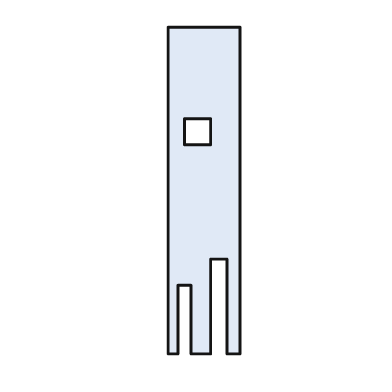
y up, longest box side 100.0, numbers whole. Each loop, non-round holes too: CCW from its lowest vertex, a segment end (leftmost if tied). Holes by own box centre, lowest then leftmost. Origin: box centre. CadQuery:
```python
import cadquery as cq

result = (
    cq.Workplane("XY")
    .moveTo(-11.0, -50.0)
    .lineTo(-8.0, -50.0)
    .lineTo(-8.0, -29.0)
    .lineTo(-4.0, -29.0)
    .lineTo(-4.0, -50.0)
    .lineTo(2.0, -50.0)
    .lineTo(2.0, -21.0)
    .lineTo(7.0, -21.0)
    .lineTo(7.0, -50.0)
    .lineTo(11.0, -50.0)
    .lineTo(11.0, 50.0)
    .lineTo(-11.0, 50.0)
    .close()
    .moveTo(-6.0, 14.0)
    .lineTo(2.0, 14.0)
    .lineTo(2.0, 22.0)
    .lineTo(-6.0, 22.0)
    .close()
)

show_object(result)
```